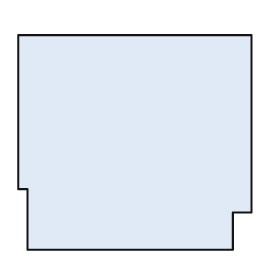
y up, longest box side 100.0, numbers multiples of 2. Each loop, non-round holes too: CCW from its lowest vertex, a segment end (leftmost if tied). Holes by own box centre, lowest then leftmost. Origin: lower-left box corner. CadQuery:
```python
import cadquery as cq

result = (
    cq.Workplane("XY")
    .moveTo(4.0, 0.0)
    .lineTo(92.0, 0.0)
    .lineTo(92.0, 16.0)
    .lineTo(100.0, 16.0)
    .lineTo(100.0, 92.0)
    .lineTo(0.0, 92.0)
    .lineTo(0.0, 26.0)
    .lineTo(4.0, 26.0)
    .close()
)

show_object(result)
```